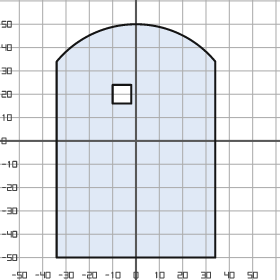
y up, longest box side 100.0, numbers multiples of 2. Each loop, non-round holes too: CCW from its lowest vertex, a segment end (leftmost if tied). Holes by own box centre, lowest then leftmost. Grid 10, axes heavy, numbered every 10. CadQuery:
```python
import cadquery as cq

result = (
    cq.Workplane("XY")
    .moveTo(-34.0, -50.0)
    .lineTo(34.0, -50.0)
    .lineTo(34.0, 34.0)
    .threePointArc((0.0, 50.0), (-34.0, 34.0))
    .close()
    .moveTo(-10.0, 16.0)
    .lineTo(-2.0, 16.0)
    .lineTo(-2.0, 24.0)
    .lineTo(-10.0, 24.0)
    .close()
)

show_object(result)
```